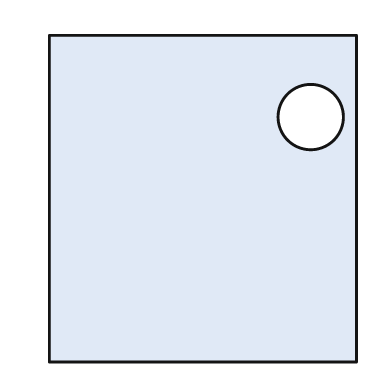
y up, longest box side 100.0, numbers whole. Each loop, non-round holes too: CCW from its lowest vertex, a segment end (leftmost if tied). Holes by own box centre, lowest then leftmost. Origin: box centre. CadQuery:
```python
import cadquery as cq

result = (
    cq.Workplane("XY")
    .moveTo(-47.0, -50.0)
    .lineTo(47.0, -50.0)
    .lineTo(47.0, 50.0)
    .lineTo(-47.0, 50.0)
    .close()
    .moveTo(33.0, 25.0)
    .circle(10.0)
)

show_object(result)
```